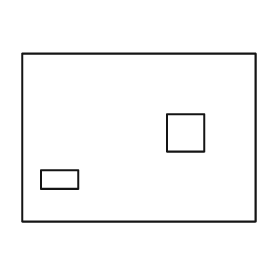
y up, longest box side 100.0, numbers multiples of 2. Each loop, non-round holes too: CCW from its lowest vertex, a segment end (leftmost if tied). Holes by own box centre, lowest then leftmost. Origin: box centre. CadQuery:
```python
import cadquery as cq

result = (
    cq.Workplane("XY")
    .moveTo(-50.0, -36.0)
    .lineTo(50.0, -36.0)
    .lineTo(50.0, 36.0)
    .lineTo(-50.0, 36.0)
    .close()
    .moveTo(-42.0, -22.0)
    .lineTo(-26.0, -22.0)
    .lineTo(-26.0, -14.0)
    .lineTo(-42.0, -14.0)
    .close()
    .moveTo(12.0, -6.0)
    .lineTo(28.0, -6.0)
    .lineTo(28.0, 10.0)
    .lineTo(12.0, 10.0)
    .close()
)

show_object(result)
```